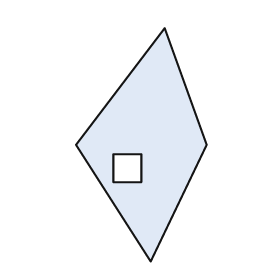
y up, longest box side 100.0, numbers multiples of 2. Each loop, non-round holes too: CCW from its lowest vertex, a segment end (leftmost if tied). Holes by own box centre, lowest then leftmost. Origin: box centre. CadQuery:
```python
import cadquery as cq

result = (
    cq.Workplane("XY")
    .moveTo(4.0, -50.0)
    .lineTo(28.0, 0.0)
    .lineTo(10.0, 50.0)
    .lineTo(-28.0, 0.0)
    .close()
    .moveTo(-12.0, -16.0)
    .lineTo(0.0, -16.0)
    .lineTo(0.0, -4.0)
    .lineTo(-12.0, -4.0)
    .close()
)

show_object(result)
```